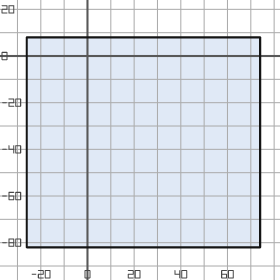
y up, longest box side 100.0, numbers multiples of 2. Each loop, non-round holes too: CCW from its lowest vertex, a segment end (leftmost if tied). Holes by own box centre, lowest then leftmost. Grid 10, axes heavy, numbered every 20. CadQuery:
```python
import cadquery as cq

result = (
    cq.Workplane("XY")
    .moveTo(-26.0, -82.0)
    .lineTo(74.0, -82.0)
    .lineTo(74.0, 8.0)
    .lineTo(-26.0, 8.0)
    .close()
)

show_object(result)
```